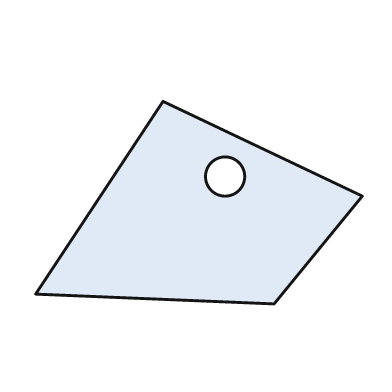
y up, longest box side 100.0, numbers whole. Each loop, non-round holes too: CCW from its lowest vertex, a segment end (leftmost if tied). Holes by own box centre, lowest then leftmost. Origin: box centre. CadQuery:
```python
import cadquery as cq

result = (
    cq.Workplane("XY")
    .moveTo(23.0, -31.0)
    .lineTo(50.0, 2.0)
    .lineTo(-11.0, 31.0)
    .lineTo(-50.0, -28.0)
    .close()
    .moveTo(8.0, 8.0)
    .circle(6.0)
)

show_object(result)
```